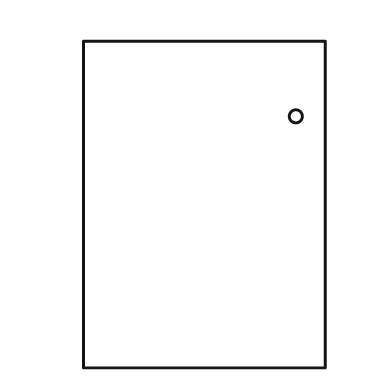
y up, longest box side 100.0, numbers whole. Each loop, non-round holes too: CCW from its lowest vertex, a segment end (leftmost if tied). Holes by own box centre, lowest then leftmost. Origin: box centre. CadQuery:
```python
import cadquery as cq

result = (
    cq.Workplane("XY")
    .moveTo(-37.0, -50.0)
    .lineTo(37.0, -50.0)
    .lineTo(37.0, 50.0)
    .lineTo(-37.0, 50.0)
    .close()
    .moveTo(28.0, 27.0)
    .circle(2.0)
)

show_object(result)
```